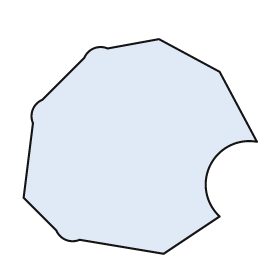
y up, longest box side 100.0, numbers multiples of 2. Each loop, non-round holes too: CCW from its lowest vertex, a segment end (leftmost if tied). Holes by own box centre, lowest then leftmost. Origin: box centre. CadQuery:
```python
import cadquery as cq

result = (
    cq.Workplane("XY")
    .moveTo(10.0, -46.0)
    .lineTo(34.0, -30.0)
    .threePointArc((30.0, -8.0), (50.0, 2.0))
    .lineTo(34.0, 32.0)
    .lineTo(8.0, 46.0)
    .lineTo(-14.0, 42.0)
    .threePointArc((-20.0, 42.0), (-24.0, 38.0))
    .lineTo(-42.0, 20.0)
    .threePointArc((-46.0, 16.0), (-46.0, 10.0))
    .lineTo(-50.0, -22.0)
    .lineTo(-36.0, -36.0)
    .threePointArc((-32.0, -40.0), (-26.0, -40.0))
    .close()
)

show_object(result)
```